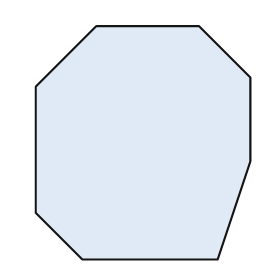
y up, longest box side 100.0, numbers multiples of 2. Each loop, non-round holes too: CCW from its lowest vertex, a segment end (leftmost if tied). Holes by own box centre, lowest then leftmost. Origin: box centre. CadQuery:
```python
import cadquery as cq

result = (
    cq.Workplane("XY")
    .moveTo(-26.0, -50.0)
    .lineTo(32.0, -50.0)
    .lineTo(46.0, -8.0)
    .lineTo(46.0, 28.0)
    .lineTo(24.0, 50.0)
    .lineTo(-20.0, 50.0)
    .lineTo(-46.0, 24.0)
    .lineTo(-46.0, -30.0)
    .close()
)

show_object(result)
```